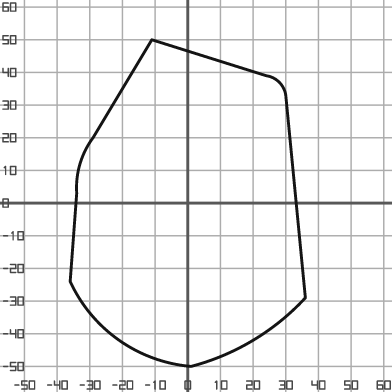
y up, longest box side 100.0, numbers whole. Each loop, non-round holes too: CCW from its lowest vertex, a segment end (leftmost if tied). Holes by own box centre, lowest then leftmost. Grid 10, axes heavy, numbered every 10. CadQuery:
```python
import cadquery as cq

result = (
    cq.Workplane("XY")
    .moveTo(1.0, -50.0)
    .threePointArc((20.0, -42.0), (36.0, -29.0))
    .lineTo(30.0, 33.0)
    .threePointArc((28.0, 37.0), (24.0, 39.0))
    .lineTo(-11.0, 50.0)
    .lineTo(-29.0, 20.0)
    .threePointArc((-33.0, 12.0), (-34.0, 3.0))
    .lineTo(-36.0, -24.0)
    .threePointArc((-21.0, -42.0), (1.0, -50.0))
    .close()
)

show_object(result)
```